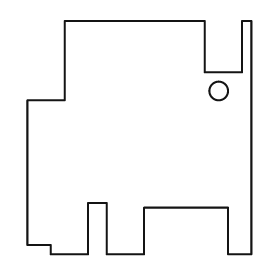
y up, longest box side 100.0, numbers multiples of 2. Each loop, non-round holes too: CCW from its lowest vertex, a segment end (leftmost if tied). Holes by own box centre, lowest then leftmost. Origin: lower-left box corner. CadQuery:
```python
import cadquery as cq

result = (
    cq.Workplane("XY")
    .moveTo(10.0, 0.0)
    .lineTo(26.0, 0.0)
    .lineTo(26.0, 22.0)
    .lineTo(34.0, 22.0)
    .lineTo(34.0, 0.0)
    .lineTo(50.0, 0.0)
    .lineTo(50.0, 20.0)
    .lineTo(86.0, 20.0)
    .lineTo(86.0, 0.0)
    .lineTo(96.0, 0.0)
    .lineTo(96.0, 100.0)
    .lineTo(92.0, 100.0)
    .lineTo(92.0, 78.0)
    .lineTo(76.0, 78.0)
    .lineTo(76.0, 100.0)
    .lineTo(16.0, 100.0)
    .lineTo(16.0, 66.0)
    .lineTo(0.0, 66.0)
    .lineTo(0.0, 4.0)
    .lineTo(10.0, 4.0)
    .close()
    .moveTo(82.0, 70.0)
    .circle(4.0)
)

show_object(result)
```